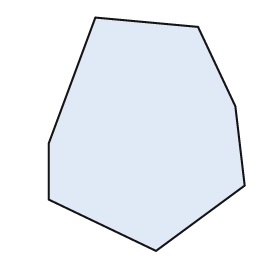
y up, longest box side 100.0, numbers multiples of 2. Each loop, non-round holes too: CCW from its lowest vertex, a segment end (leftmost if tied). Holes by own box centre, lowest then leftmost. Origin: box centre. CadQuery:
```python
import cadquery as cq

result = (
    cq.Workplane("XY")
    .moveTo(4.0, -50.0)
    .lineTo(42.0, -22.0)
    .lineTo(38.0, 12.0)
    .lineTo(22.0, 46.0)
    .lineTo(-22.0, 50.0)
    .lineTo(-42.0, -4.0)
    .lineTo(-42.0, -28.0)
    .close()
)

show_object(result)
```